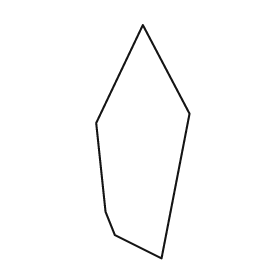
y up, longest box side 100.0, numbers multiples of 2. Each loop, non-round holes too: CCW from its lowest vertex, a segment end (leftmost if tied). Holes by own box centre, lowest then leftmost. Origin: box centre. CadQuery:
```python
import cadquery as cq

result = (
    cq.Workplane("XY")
    .moveTo(8.0, -50.0)
    .lineTo(20.0, 12.0)
    .lineTo(0.0, 50.0)
    .lineTo(-20.0, 8.0)
    .lineTo(-16.0, -30.0)
    .lineTo(-12.0, -40.0)
    .close()
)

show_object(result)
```